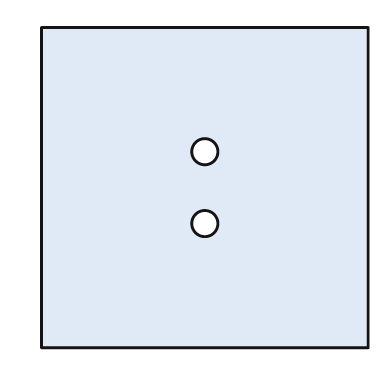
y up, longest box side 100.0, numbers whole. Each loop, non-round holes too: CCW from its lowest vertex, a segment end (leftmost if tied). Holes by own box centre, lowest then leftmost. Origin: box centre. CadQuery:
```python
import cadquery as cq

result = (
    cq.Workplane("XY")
    .moveTo(-50.0, -49.0)
    .lineTo(50.0, -49.0)
    .lineTo(50.0, 49.0)
    .lineTo(-50.0, 49.0)
    .close()
    .moveTo(0.0, -11.0)
    .circle(4.0)
    .moveTo(0.0, 11.0)
    .circle(4.0)
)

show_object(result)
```